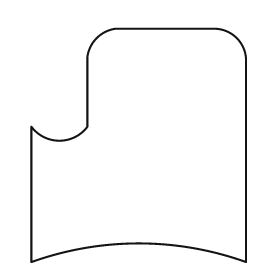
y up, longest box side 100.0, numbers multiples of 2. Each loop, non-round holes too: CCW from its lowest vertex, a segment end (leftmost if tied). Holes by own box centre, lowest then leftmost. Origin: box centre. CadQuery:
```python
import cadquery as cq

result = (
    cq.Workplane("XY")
    .moveTo(-46.0, -50.0)
    .threePointArc((0.0, -42.0), (46.0, -50.0))
    .lineTo(46.0, 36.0)
    .threePointArc((42.0, 46.0), (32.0, 50.0))
    .lineTo(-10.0, 50.0)
    .threePointArc((-18.0, 46.0), (-22.0, 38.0))
    .lineTo(-22.0, 8.0)
    .threePointArc((-34.0, 2.0), (-46.0, 8.0))
    .close()
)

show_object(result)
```